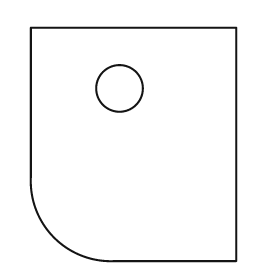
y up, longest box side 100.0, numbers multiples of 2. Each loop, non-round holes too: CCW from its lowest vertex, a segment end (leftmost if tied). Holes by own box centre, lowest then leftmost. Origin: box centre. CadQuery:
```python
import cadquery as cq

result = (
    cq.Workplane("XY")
    .moveTo(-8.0, -50.0)
    .lineTo(44.0, -50.0)
    .lineTo(44.0, 50.0)
    .lineTo(-44.0, 50.0)
    .lineTo(-44.0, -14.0)
    .threePointArc((-34.0, -40.0), (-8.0, -50.0))
    .close()
    .moveTo(-6.0, 24.0)
    .circle(10.0)
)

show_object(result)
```